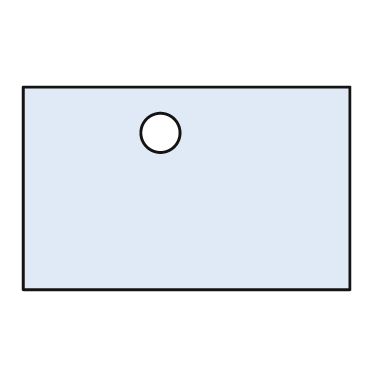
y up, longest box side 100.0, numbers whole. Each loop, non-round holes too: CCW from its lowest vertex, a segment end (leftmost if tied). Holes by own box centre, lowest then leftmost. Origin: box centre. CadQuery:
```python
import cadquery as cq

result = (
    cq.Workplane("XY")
    .moveTo(-50.0, -31.0)
    .lineTo(50.0, -31.0)
    .lineTo(50.0, 31.0)
    .lineTo(-50.0, 31.0)
    .close()
    .moveTo(-8.0, 17.0)
    .circle(6.0)
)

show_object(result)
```